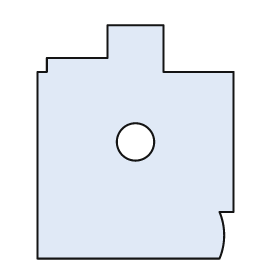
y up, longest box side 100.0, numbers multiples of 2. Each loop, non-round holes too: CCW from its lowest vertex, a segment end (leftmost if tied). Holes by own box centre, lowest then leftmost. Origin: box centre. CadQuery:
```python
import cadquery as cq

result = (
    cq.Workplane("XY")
    .moveTo(-42.0, -50.0)
    .lineTo(36.0, -50.0)
    .threePointArc((38.0, -40.0), (36.0, -30.0))
    .lineTo(42.0, -30.0)
    .lineTo(42.0, 30.0)
    .lineTo(12.0, 30.0)
    .lineTo(12.0, 50.0)
    .lineTo(-12.0, 50.0)
    .lineTo(-12.0, 36.0)
    .lineTo(-38.0, 36.0)
    .lineTo(-38.0, 30.0)
    .lineTo(-42.0, 30.0)
    .close()
    .moveTo(0.0, 0.0)
    .circle(8.0)
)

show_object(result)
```